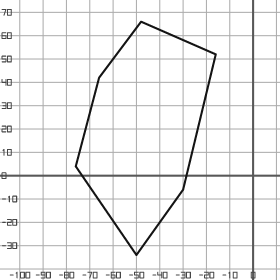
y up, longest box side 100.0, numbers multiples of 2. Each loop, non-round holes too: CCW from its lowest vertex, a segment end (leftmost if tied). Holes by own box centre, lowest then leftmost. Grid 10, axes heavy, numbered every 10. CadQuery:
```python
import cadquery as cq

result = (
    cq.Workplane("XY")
    .moveTo(-50.0, -34.0)
    .lineTo(-30.0, -6.0)
    .lineTo(-16.0, 52.0)
    .lineTo(-48.0, 66.0)
    .lineTo(-66.0, 42.0)
    .lineTo(-76.0, 4.0)
    .close()
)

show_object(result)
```